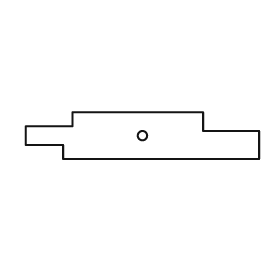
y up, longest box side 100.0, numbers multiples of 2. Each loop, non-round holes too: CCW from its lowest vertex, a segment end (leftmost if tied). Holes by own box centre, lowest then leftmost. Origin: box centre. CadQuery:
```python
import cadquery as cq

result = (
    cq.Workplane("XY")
    .moveTo(-34.0, -10.0)
    .lineTo(50.0, -10.0)
    .lineTo(50.0, 2.0)
    .lineTo(26.0, 2.0)
    .lineTo(26.0, 10.0)
    .lineTo(-30.0, 10.0)
    .lineTo(-30.0, 4.0)
    .lineTo(-50.0, 4.0)
    .lineTo(-50.0, -4.0)
    .lineTo(-34.0, -4.0)
    .close()
    .moveTo(0.0, 0.0)
    .circle(2.0)
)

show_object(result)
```